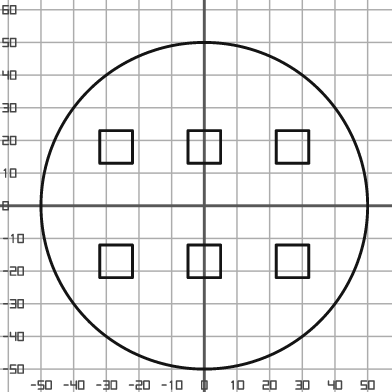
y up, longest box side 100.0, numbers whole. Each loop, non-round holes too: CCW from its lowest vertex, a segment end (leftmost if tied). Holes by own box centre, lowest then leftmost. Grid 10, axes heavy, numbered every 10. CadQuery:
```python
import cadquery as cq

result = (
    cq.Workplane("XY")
    .moveTo(0.0, 0.0)
    .circle(50.0)
    .moveTo(-32.0, -22.0)
    .lineTo(-22.0, -22.0)
    .lineTo(-22.0, -12.0)
    .lineTo(-32.0, -12.0)
    .close()
    .moveTo(-5.0, -22.0)
    .lineTo(5.0, -22.0)
    .lineTo(5.0, -12.0)
    .lineTo(-5.0, -12.0)
    .close()
    .moveTo(22.0, -22.0)
    .lineTo(32.0, -22.0)
    .lineTo(32.0, -12.0)
    .lineTo(22.0, -12.0)
    .close()
    .moveTo(-32.0, 13.0)
    .lineTo(-22.0, 13.0)
    .lineTo(-22.0, 23.0)
    .lineTo(-32.0, 23.0)
    .close()
    .moveTo(-5.0, 13.0)
    .lineTo(5.0, 13.0)
    .lineTo(5.0, 23.0)
    .lineTo(-5.0, 23.0)
    .close()
    .moveTo(22.0, 13.0)
    .lineTo(32.0, 13.0)
    .lineTo(32.0, 23.0)
    .lineTo(22.0, 23.0)
    .close()
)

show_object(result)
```